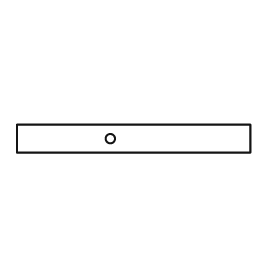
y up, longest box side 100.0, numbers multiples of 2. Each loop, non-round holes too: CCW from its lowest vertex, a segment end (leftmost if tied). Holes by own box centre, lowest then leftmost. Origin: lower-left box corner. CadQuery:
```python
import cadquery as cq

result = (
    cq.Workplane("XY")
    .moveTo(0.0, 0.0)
    .lineTo(100.0, 0.0)
    .lineTo(100.0, 12.0)
    .lineTo(0.0, 12.0)
    .close()
    .moveTo(40.0, 6.0)
    .circle(2.0)
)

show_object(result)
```